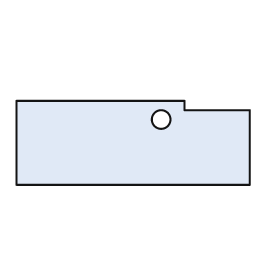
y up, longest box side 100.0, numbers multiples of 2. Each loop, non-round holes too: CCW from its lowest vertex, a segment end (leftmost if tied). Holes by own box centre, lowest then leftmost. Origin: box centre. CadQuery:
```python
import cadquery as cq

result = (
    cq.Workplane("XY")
    .moveTo(-50.0, -18.0)
    .lineTo(50.0, -18.0)
    .lineTo(50.0, 14.0)
    .lineTo(22.0, 14.0)
    .lineTo(22.0, 18.0)
    .lineTo(-50.0, 18.0)
    .close()
    .moveTo(12.0, 10.0)
    .circle(4.0)
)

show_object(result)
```